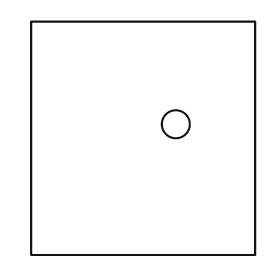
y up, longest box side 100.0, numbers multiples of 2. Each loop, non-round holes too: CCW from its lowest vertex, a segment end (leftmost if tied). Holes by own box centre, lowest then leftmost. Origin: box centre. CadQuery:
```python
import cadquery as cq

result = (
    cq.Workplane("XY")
    .moveTo(-48.0, -50.0)
    .lineTo(48.0, -50.0)
    .lineTo(48.0, 50.0)
    .lineTo(-48.0, 50.0)
    .close()
    .moveTo(14.0, 6.0)
    .circle(6.0)
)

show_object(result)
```